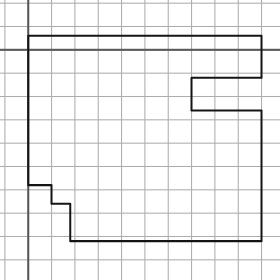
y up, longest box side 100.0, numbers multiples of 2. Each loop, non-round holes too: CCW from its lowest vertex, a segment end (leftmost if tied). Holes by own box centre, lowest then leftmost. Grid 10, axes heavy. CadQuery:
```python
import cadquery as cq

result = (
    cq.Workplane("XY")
    .moveTo(18.0, -82.0)
    .lineTo(100.0, -82.0)
    .lineTo(100.0, -26.0)
    .lineTo(70.0, -26.0)
    .lineTo(70.0, -12.0)
    .lineTo(100.0, -12.0)
    .lineTo(100.0, 6.0)
    .lineTo(0.0, 6.0)
    .lineTo(0.0, -58.0)
    .lineTo(10.0, -58.0)
    .lineTo(10.0, -66.0)
    .lineTo(18.0, -66.0)
    .close()
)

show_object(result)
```